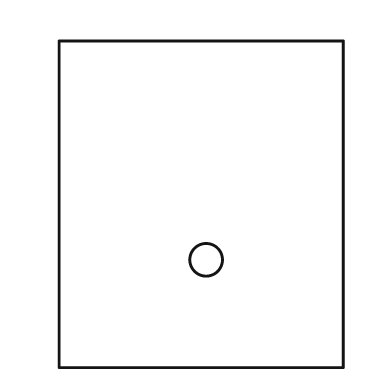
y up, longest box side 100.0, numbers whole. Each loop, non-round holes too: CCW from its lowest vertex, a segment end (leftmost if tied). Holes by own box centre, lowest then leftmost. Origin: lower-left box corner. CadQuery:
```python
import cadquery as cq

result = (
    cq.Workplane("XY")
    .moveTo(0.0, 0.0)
    .lineTo(87.0, 0.0)
    .lineTo(87.0, 100.0)
    .lineTo(0.0, 100.0)
    .close()
    .moveTo(45.0, 33.0)
    .circle(5.0)
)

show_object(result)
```